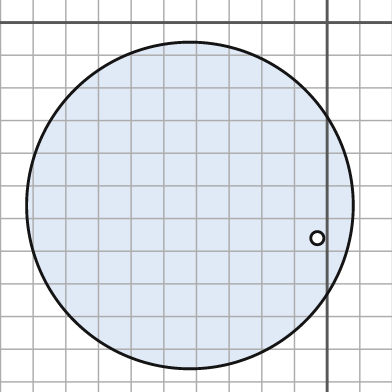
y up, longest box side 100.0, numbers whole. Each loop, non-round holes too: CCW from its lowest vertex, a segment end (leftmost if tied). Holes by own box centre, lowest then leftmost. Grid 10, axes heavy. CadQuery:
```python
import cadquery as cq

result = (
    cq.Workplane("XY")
    .moveTo(-42.0, -56.0)
    .circle(50.0)
    .moveTo(-3.0, -66.0)
    .circle(2.0)
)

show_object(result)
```